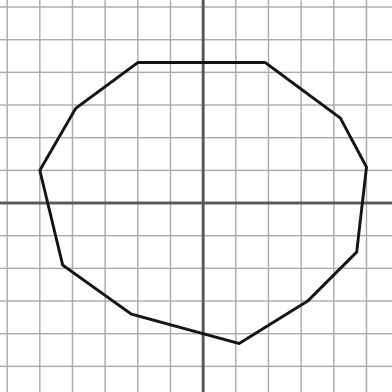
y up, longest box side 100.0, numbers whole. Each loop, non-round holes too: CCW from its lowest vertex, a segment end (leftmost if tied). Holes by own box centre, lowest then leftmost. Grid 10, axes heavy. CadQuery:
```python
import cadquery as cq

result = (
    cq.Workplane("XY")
    .moveTo(11.0, -43.0)
    .lineTo(32.0, -30.0)
    .lineTo(47.0, -15.0)
    .lineTo(50.0, 11.0)
    .lineTo(42.0, 26.0)
    .lineTo(19.0, 43.0)
    .lineTo(-20.0, 43.0)
    .lineTo(-39.0, 29.0)
    .lineTo(-50.0, 10.0)
    .lineTo(-43.0, -19.0)
    .lineTo(-22.0, -34.0)
    .close()
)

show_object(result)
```